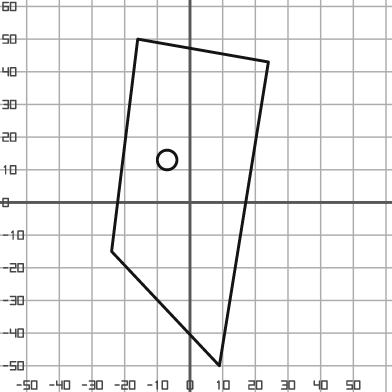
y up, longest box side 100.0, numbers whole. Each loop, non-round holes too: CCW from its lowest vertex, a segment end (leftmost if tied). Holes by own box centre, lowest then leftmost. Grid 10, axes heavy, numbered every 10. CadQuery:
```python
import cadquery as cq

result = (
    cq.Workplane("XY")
    .moveTo(9.0, -50.0)
    .lineTo(24.0, 43.0)
    .lineTo(-16.0, 50.0)
    .lineTo(-24.0, -15.0)
    .close()
    .moveTo(-7.0, 13.0)
    .circle(3.0)
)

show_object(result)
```